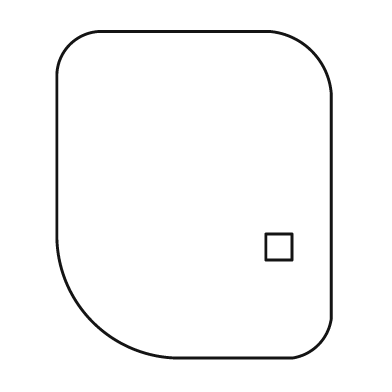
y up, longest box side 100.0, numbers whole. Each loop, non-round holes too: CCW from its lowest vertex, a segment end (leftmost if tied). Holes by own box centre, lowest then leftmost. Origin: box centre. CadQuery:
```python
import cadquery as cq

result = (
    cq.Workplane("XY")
    .moveTo(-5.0, -50.0)
    .lineTo(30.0, -50.0)
    .threePointArc((38.0, -46.0), (42.0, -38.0))
    .lineTo(42.0, 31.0)
    .threePointArc((36.0, 44.0), (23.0, 50.0))
    .lineTo(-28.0, 50.0)
    .threePointArc((-38.0, 46.0), (-42.0, 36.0))
    .lineTo(-42.0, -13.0)
    .threePointArc((-31.0, -39.0), (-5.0, -50.0))
    .close()
    .moveTo(22.0, -20.0)
    .lineTo(30.0, -20.0)
    .lineTo(30.0, -12.0)
    .lineTo(22.0, -12.0)
    .close()
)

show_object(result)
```